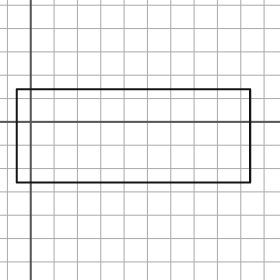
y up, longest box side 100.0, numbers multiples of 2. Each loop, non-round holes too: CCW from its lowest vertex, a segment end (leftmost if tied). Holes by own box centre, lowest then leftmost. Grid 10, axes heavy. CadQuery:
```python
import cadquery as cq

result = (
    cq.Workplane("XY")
    .moveTo(-6.0, -26.0)
    .lineTo(94.0, -26.0)
    .lineTo(94.0, 14.0)
    .lineTo(-6.0, 14.0)
    .close()
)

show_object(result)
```